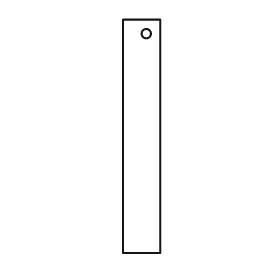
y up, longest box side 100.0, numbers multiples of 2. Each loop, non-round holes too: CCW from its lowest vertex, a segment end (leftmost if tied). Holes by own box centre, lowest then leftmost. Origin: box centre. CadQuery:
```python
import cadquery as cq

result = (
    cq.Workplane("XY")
    .moveTo(-8.0, -50.0)
    .lineTo(8.0, -50.0)
    .lineTo(8.0, 50.0)
    .lineTo(-8.0, 50.0)
    .close()
    .moveTo(2.0, 44.0)
    .circle(2.0)
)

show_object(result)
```